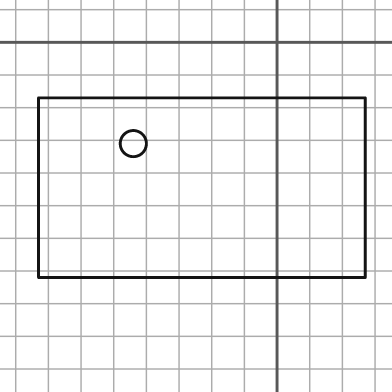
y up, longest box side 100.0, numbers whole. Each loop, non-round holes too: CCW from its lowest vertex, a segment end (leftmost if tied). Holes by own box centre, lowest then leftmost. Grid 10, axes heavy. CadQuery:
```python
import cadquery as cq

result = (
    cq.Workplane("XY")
    .moveTo(-73.0, -72.0)
    .lineTo(27.0, -72.0)
    .lineTo(27.0, -17.0)
    .lineTo(-73.0, -17.0)
    .close()
    .moveTo(-44.0, -31.0)
    .circle(4.0)
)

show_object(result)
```